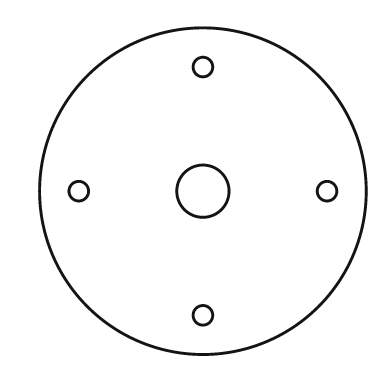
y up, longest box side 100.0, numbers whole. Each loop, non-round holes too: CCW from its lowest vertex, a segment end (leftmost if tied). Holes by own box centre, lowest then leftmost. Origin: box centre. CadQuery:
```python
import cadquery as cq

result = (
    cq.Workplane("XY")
    .moveTo(0.0, 0.0)
    .circle(50.0)
    .moveTo(0.0, -38.0)
    .circle(3.0)
    .moveTo(-38.0, 0.0)
    .circle(3.0)
    .moveTo(0.0, 0.0)
    .circle(8.0)
    .moveTo(38.0, 0.0)
    .circle(3.0)
    .moveTo(0.0, 38.0)
    .circle(3.0)
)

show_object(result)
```